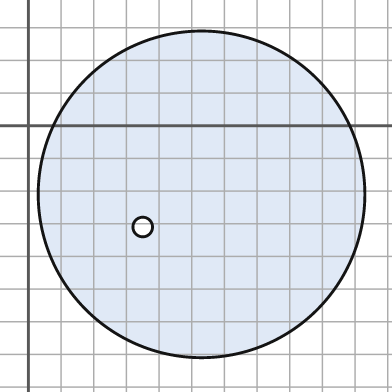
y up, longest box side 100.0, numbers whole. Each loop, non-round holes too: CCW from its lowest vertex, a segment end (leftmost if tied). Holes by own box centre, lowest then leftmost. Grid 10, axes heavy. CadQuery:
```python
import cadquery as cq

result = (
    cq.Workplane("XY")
    .moveTo(53.0, -21.0)
    .circle(50.0)
    .moveTo(35.0, -31.0)
    .circle(3.0)
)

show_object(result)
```